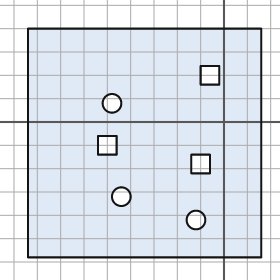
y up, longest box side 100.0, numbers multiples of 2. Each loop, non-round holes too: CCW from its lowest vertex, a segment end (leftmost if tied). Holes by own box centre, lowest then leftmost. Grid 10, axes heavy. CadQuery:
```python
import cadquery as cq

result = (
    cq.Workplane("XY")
    .moveTo(-84.0, -58.0)
    .lineTo(16.0, -58.0)
    .lineTo(16.0, 40.0)
    .lineTo(-84.0, 40.0)
    .close()
    .moveTo(-12.0, -42.0)
    .circle(4.0)
    .moveTo(-44.0, -32.0)
    .circle(4.0)
    .moveTo(-14.0, -22.0)
    .lineTo(-6.0, -22.0)
    .lineTo(-6.0, -14.0)
    .lineTo(-14.0, -14.0)
    .close()
    .moveTo(-54.0, -14.0)
    .lineTo(-46.0, -14.0)
    .lineTo(-46.0, -6.0)
    .lineTo(-54.0, -6.0)
    .close()
    .moveTo(-48.0, 8.0)
    .circle(4.0)
    .moveTo(-10.0, 16.0)
    .lineTo(-2.0, 16.0)
    .lineTo(-2.0, 24.0)
    .lineTo(-10.0, 24.0)
    .close()
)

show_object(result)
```